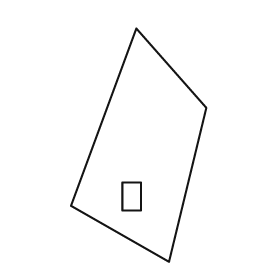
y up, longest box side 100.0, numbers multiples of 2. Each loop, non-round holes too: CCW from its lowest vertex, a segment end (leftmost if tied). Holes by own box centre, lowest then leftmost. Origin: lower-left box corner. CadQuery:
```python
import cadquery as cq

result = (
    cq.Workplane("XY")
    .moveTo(42.0, 0.0)
    .lineTo(58.0, 66.0)
    .lineTo(28.0, 100.0)
    .lineTo(0.0, 24.0)
    .close()
    .moveTo(22.0, 22.0)
    .lineTo(30.0, 22.0)
    .lineTo(30.0, 34.0)
    .lineTo(22.0, 34.0)
    .close()
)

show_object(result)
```